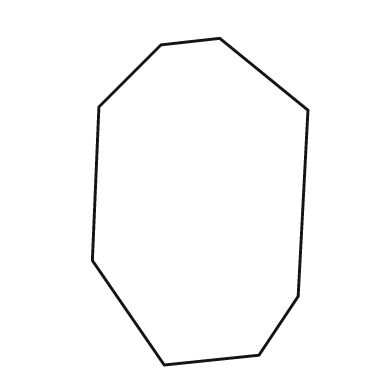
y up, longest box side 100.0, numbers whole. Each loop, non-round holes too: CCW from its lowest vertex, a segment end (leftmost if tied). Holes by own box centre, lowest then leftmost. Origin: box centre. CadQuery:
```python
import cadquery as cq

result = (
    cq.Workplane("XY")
    .moveTo(-11.0, -50.0)
    .lineTo(18.0, -47.0)
    .lineTo(30.0, -29.0)
    .lineTo(33.0, 28.0)
    .lineTo(6.0, 50.0)
    .lineTo(-12.0, 48.0)
    .lineTo(-31.0, 29.0)
    .lineTo(-33.0, -18.0)
    .close()
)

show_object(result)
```